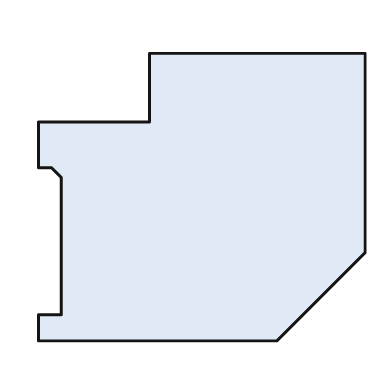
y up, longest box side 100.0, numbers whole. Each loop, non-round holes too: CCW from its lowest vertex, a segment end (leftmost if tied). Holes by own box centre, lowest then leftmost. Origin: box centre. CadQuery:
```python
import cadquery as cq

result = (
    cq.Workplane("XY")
    .moveTo(-50.0, -44.0)
    .lineTo(23.0, -44.0)
    .lineTo(50.0, -17.0)
    .lineTo(50.0, 44.0)
    .lineTo(-16.0, 44.0)
    .lineTo(-16.0, 23.0)
    .lineTo(-50.0, 23.0)
    .lineTo(-50.0, 9.0)
    .lineTo(-46.0, 9.0)
    .lineTo(-43.0, 6.0)
    .lineTo(-43.0, -36.0)
    .lineTo(-50.0, -36.0)
    .close()
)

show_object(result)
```